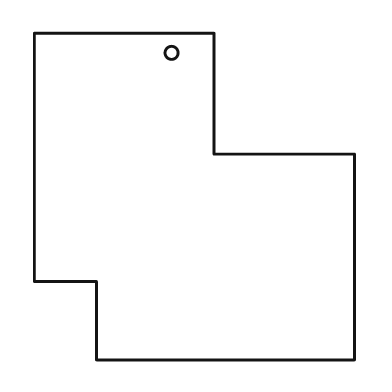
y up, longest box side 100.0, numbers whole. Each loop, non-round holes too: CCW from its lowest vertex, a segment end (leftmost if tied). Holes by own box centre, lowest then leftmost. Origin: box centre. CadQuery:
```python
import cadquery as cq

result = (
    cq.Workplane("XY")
    .moveTo(-30.0, -50.0)
    .lineTo(49.0, -50.0)
    .lineTo(49.0, 13.0)
    .lineTo(6.0, 13.0)
    .lineTo(6.0, 50.0)
    .lineTo(-49.0, 50.0)
    .lineTo(-49.0, -26.0)
    .lineTo(-30.0, -26.0)
    .close()
    .moveTo(-7.0, 44.0)
    .circle(2.0)
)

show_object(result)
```